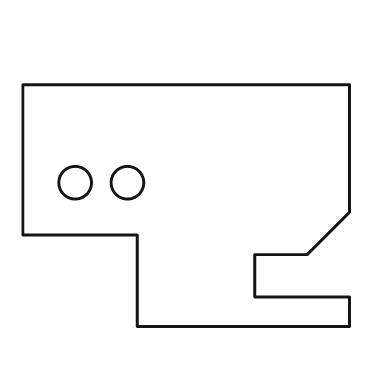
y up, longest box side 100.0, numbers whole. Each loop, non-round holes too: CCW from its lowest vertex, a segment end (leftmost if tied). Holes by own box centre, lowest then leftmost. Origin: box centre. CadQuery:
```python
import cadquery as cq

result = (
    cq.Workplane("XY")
    .moveTo(-15.0, -37.0)
    .lineTo(50.0, -37.0)
    .lineTo(50.0, -28.0)
    .lineTo(21.0, -28.0)
    .lineTo(21.0, -15.0)
    .lineTo(37.0, -15.0)
    .lineTo(50.0, -2.0)
    .lineTo(50.0, 37.0)
    .lineTo(-50.0, 37.0)
    .lineTo(-50.0, -9.0)
    .lineTo(-15.0, -9.0)
    .close()
    .moveTo(-34.0, 7.0)
    .circle(5.0)
    .moveTo(-18.0, 7.0)
    .circle(5.0)
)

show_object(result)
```